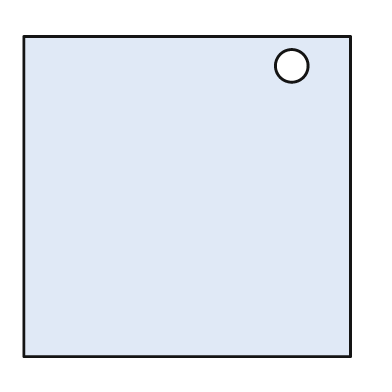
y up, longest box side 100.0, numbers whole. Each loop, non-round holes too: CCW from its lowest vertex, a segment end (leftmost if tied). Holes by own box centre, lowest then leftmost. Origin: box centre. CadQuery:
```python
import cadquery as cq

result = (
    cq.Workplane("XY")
    .moveTo(-50.0, -49.0)
    .lineTo(50.0, -49.0)
    .lineTo(50.0, 49.0)
    .lineTo(-50.0, 49.0)
    .close()
    .moveTo(32.0, 40.0)
    .circle(5.0)
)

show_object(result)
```